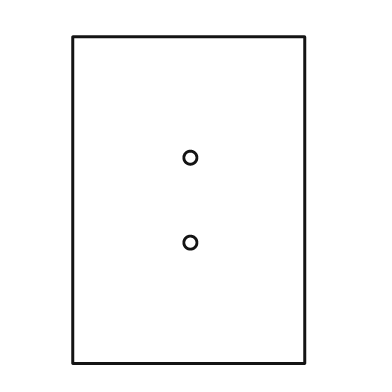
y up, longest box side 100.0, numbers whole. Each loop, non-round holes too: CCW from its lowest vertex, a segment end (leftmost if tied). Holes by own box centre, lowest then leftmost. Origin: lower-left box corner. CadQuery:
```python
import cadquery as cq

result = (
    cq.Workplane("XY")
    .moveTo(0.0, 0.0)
    .lineTo(71.0, 0.0)
    .lineTo(71.0, 100.0)
    .lineTo(0.0, 100.0)
    .close()
    .moveTo(36.0, 37.0)
    .circle(2.0)
    .moveTo(36.0, 63.0)
    .circle(2.0)
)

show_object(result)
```